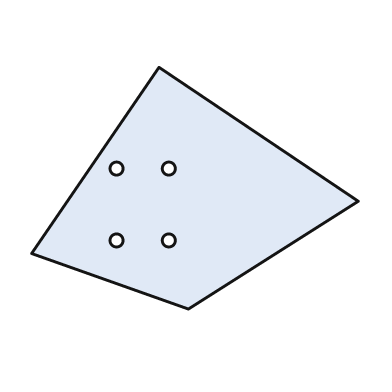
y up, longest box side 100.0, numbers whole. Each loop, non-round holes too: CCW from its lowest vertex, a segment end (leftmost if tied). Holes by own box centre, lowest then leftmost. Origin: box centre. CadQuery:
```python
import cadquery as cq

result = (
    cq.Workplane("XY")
    .moveTo(-2.0, -37.0)
    .lineTo(50.0, -4.0)
    .lineTo(-11.0, 37.0)
    .lineTo(-50.0, -20.0)
    .close()
    .moveTo(-24.0, -16.0)
    .circle(2.0)
    .moveTo(-8.0, -16.0)
    .circle(2.0)
    .moveTo(-24.0, 6.0)
    .circle(2.0)
    .moveTo(-8.0, 6.0)
    .circle(2.0)
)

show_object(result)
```